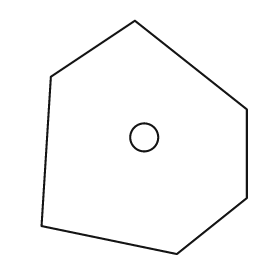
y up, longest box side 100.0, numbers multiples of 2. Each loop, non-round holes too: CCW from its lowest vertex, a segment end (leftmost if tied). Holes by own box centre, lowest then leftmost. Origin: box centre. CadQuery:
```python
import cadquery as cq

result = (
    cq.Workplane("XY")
    .moveTo(14.0, -50.0)
    .lineTo(44.0, -26.0)
    .lineTo(44.0, 12.0)
    .lineTo(-4.0, 50.0)
    .lineTo(-40.0, 26.0)
    .lineTo(-44.0, -38.0)
    .close()
    .moveTo(0.0, 0.0)
    .circle(6.0)
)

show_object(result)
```